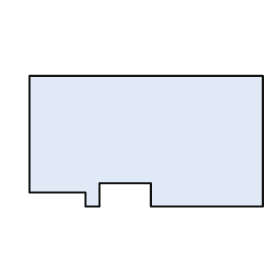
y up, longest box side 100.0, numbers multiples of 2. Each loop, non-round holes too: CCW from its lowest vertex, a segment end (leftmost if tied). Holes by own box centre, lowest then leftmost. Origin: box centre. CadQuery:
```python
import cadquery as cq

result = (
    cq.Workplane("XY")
    .moveTo(-26.0, -28.0)
    .lineTo(-20.0, -28.0)
    .lineTo(-20.0, -18.0)
    .lineTo(2.0, -18.0)
    .lineTo(2.0, -28.0)
    .lineTo(50.0, -28.0)
    .lineTo(50.0, 28.0)
    .lineTo(-50.0, 28.0)
    .lineTo(-50.0, -22.0)
    .lineTo(-26.0, -22.0)
    .close()
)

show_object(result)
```